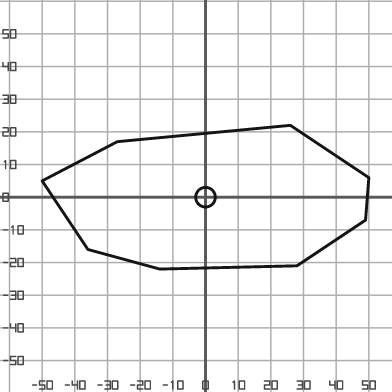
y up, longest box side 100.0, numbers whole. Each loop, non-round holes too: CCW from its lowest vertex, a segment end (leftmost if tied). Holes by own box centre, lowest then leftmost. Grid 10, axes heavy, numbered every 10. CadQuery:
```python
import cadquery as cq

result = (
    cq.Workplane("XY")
    .moveTo(-14.0, -22.0)
    .lineTo(28.0, -21.0)
    .lineTo(49.0, -7.0)
    .lineTo(50.0, 6.0)
    .lineTo(26.0, 22.0)
    .lineTo(-27.0, 17.0)
    .lineTo(-50.0, 5.0)
    .lineTo(-36.0, -16.0)
    .close()
    .moveTo(0.0, 0.0)
    .circle(3.0)
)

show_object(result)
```